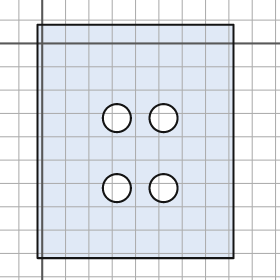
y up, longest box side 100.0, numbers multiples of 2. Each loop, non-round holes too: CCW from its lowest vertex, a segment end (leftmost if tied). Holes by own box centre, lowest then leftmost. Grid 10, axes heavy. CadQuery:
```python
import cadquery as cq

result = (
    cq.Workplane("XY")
    .moveTo(-2.0, -92.0)
    .lineTo(82.0, -92.0)
    .lineTo(82.0, 8.0)
    .lineTo(-2.0, 8.0)
    .close()
    .moveTo(32.0, -62.0)
    .circle(6.0)
    .moveTo(52.0, -62.0)
    .circle(6.0)
    .moveTo(32.0, -32.0)
    .circle(6.0)
    .moveTo(52.0, -32.0)
    .circle(6.0)
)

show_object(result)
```